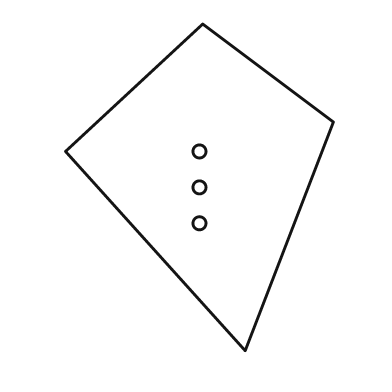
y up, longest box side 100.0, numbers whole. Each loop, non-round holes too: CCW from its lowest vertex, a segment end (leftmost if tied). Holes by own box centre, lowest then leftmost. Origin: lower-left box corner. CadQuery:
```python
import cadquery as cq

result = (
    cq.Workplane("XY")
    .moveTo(55.0, 0.0)
    .lineTo(82.0, 70.0)
    .lineTo(42.0, 100.0)
    .lineTo(0.0, 61.0)
    .close()
    .moveTo(41.0, 39.0)
    .circle(2.0)
    .moveTo(41.0, 50.0)
    .circle(2.0)
    .moveTo(41.0, 61.0)
    .circle(2.0)
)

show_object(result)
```